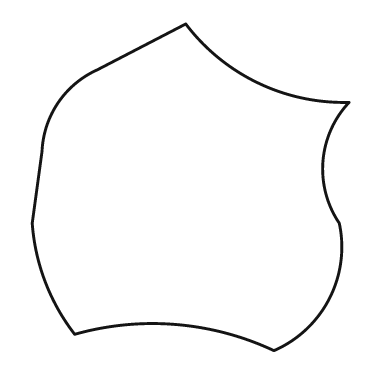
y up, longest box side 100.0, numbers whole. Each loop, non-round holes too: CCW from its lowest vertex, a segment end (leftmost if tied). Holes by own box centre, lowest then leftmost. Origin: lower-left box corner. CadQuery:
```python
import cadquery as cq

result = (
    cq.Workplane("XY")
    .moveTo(74.0, 0.0)
    .threePointArc((91.0, 16.0), (94.0, 39.0))
    .threePointArc((89.0, 58.0), (97.0, 76.0))
    .threePointArc((69.0, 82.0), (47.0, 100.0))
    .lineTo(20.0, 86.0)
    .threePointArc((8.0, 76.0), (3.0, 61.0))
    .lineTo(0.0, 39.0)
    .threePointArc((4.0, 21.0), (13.0, 5.0))
    .threePointArc((44.0, 8.0), (74.0, 0.0))
    .close()
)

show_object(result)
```